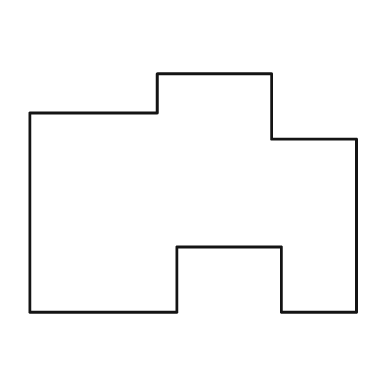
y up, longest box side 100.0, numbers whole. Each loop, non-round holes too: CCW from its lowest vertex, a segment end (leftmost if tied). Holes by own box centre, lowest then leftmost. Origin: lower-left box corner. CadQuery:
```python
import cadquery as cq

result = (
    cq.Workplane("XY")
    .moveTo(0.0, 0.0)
    .lineTo(45.0, 0.0)
    .lineTo(45.0, 20.0)
    .lineTo(77.0, 20.0)
    .lineTo(77.0, 0.0)
    .lineTo(100.0, 0.0)
    .lineTo(100.0, 53.0)
    .lineTo(74.0, 53.0)
    .lineTo(74.0, 73.0)
    .lineTo(39.0, 73.0)
    .lineTo(39.0, 61.0)
    .lineTo(0.0, 61.0)
    .close()
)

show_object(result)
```